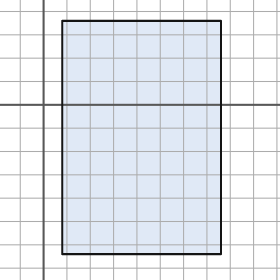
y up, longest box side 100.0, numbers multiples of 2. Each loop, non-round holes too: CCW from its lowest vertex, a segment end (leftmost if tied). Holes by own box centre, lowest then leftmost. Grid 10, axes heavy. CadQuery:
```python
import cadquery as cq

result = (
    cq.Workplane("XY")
    .moveTo(8.0, -64.0)
    .lineTo(76.0, -64.0)
    .lineTo(76.0, 36.0)
    .lineTo(8.0, 36.0)
    .close()
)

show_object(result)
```